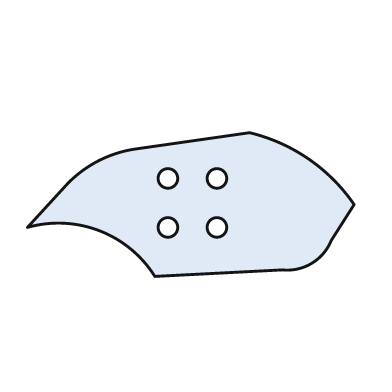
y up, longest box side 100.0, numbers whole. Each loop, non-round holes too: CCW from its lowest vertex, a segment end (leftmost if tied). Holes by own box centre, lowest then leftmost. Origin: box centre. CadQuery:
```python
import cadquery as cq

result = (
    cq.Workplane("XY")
    .moveTo(-11.0, -22.0)
    .lineTo(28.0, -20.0)
    .threePointArc((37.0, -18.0), (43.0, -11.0))
    .lineTo(50.0, 0.0)
    .threePointArc((36.0, 14.0), (18.0, 22.0))
    .lineTo(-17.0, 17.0)
    .threePointArc((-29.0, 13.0), (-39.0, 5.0))
    .lineTo(-50.0, -7.0)
    .threePointArc((-28.0, -8.0), (-11.0, -22.0))
    .close()
    .moveTo(-7.0, -7.0)
    .circle(3.0)
    .moveTo(8.0, -7.0)
    .circle(3.0)
    .moveTo(-7.0, 8.0)
    .circle(3.0)
    .moveTo(8.0, 8.0)
    .circle(3.0)
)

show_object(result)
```